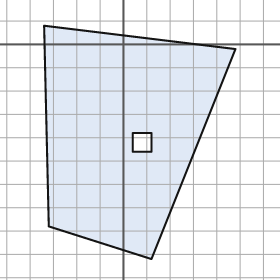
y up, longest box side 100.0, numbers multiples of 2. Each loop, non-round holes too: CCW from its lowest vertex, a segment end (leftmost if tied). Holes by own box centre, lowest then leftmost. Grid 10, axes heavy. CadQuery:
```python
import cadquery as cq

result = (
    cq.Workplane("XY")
    .moveTo(12.0, -92.0)
    .lineTo(48.0, -2.0)
    .lineTo(-34.0, 8.0)
    .lineTo(-32.0, -78.0)
    .close()
    .moveTo(4.0, -46.0)
    .lineTo(12.0, -46.0)
    .lineTo(12.0, -38.0)
    .lineTo(4.0, -38.0)
    .close()
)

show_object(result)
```